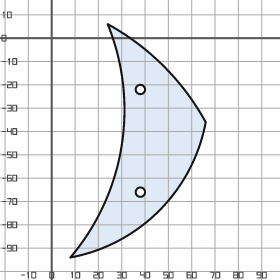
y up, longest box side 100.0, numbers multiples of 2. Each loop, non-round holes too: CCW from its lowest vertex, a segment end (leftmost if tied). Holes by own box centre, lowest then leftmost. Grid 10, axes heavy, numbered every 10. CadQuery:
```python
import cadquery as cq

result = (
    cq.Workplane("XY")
    .moveTo(8.0, -94.0)
    .threePointArc((46.0, -74.0), (66.0, -36.0))
    .threePointArc((48.0, -12.0), (24.0, 6.0))
    .threePointArc((30.0, -46.0), (8.0, -94.0))
    .close()
    .moveTo(38.0, -66.0)
    .circle(2.0)
    .moveTo(38.0, -22.0)
    .circle(2.0)
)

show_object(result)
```